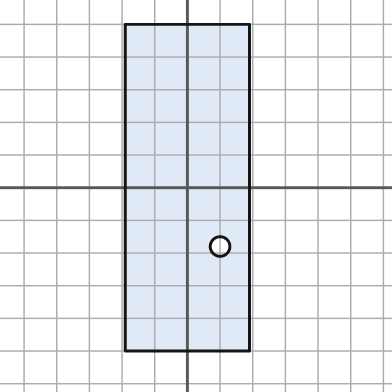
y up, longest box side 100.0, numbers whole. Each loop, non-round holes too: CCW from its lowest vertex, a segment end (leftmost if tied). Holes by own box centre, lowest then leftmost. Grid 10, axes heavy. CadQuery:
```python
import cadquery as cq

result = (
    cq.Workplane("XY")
    .moveTo(-19.0, -50.0)
    .lineTo(19.0, -50.0)
    .lineTo(19.0, 50.0)
    .lineTo(-19.0, 50.0)
    .close()
    .moveTo(10.0, -18.0)
    .circle(3.0)
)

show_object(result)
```